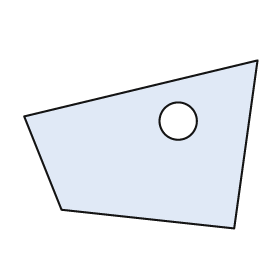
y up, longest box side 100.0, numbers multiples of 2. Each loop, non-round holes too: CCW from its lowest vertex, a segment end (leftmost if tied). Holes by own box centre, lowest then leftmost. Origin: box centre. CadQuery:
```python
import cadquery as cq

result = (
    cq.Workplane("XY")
    .moveTo(40.0, -36.0)
    .lineTo(50.0, 36.0)
    .lineTo(-50.0, 12.0)
    .lineTo(-34.0, -28.0)
    .close()
    .moveTo(16.0, 10.0)
    .circle(8.0)
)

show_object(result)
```